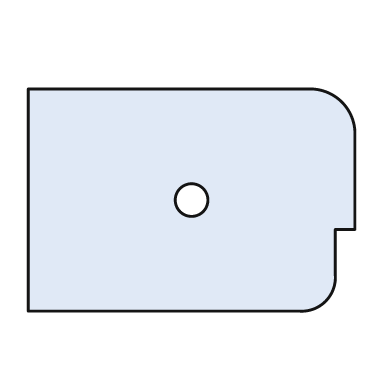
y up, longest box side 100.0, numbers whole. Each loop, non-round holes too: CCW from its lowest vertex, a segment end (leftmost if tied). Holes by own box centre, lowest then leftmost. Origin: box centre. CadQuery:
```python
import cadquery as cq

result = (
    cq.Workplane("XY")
    .moveTo(-50.0, -34.0)
    .lineTo(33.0, -34.0)
    .threePointArc((41.0, -31.0), (44.0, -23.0))
    .lineTo(44.0, -9.0)
    .lineTo(50.0, -9.0)
    .lineTo(50.0, 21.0)
    .threePointArc((46.0, 30.0), (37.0, 34.0))
    .lineTo(-50.0, 34.0)
    .close()
    .moveTo(0.0, 0.0)
    .circle(5.0)
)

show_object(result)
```